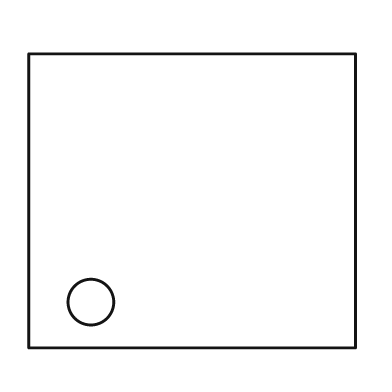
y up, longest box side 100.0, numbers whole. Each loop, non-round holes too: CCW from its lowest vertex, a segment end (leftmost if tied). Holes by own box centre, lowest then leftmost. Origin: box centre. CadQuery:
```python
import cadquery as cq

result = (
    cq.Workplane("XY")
    .moveTo(-50.0, -45.0)
    .lineTo(50.0, -45.0)
    .lineTo(50.0, 45.0)
    .lineTo(-50.0, 45.0)
    .close()
    .moveTo(-31.0, -31.0)
    .circle(7.0)
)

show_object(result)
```